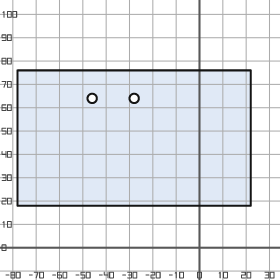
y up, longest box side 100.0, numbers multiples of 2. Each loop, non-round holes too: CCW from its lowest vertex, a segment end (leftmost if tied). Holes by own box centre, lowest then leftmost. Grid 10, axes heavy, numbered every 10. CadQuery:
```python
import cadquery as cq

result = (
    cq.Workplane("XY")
    .moveTo(-78.0, 18.0)
    .lineTo(22.0, 18.0)
    .lineTo(22.0, 76.0)
    .lineTo(-78.0, 76.0)
    .close()
    .moveTo(-46.0, 64.0)
    .circle(2.0)
    .moveTo(-28.0, 64.0)
    .circle(2.0)
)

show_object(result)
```